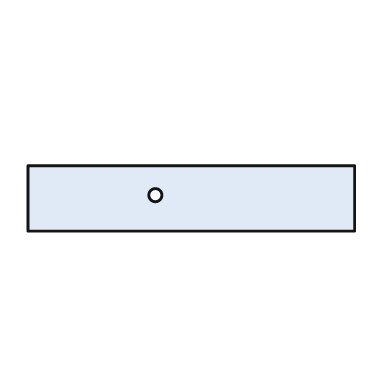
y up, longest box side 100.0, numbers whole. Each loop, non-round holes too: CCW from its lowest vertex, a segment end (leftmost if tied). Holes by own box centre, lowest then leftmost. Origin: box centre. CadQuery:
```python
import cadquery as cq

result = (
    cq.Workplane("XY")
    .moveTo(-50.0, -10.0)
    .lineTo(50.0, -10.0)
    .lineTo(50.0, 10.0)
    .lineTo(-50.0, 10.0)
    .close()
    .moveTo(-11.0, 1.0)
    .circle(2.0)
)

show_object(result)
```